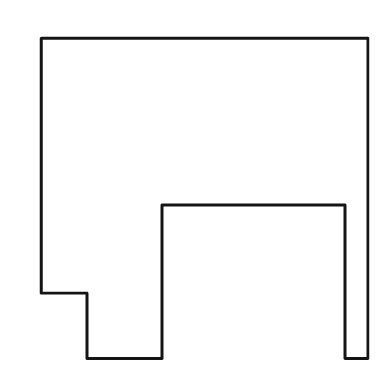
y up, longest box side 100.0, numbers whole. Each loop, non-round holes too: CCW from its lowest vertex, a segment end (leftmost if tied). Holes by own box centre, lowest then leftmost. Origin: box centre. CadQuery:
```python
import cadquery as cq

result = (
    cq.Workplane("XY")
    .moveTo(-36.0, -49.0)
    .lineTo(-13.0, -49.0)
    .lineTo(-13.0, -2.0)
    .lineTo(43.0, -2.0)
    .lineTo(43.0, -49.0)
    .lineTo(50.0, -49.0)
    .lineTo(50.0, 49.0)
    .lineTo(-50.0, 49.0)
    .lineTo(-50.0, -29.0)
    .lineTo(-36.0, -29.0)
    .close()
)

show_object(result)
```